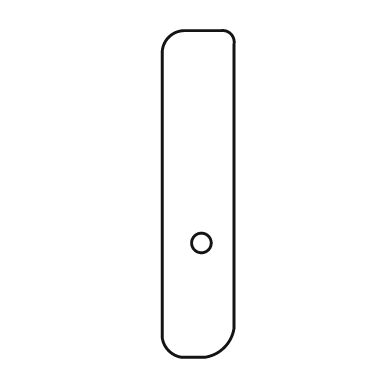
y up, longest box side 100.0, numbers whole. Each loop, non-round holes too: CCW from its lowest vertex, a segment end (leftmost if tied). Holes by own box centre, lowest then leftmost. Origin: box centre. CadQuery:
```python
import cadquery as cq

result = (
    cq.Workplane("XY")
    .moveTo(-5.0, -50.0)
    .lineTo(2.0, -50.0)
    .threePointArc((8.0, -47.0), (11.0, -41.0))
    .lineTo(11.0, 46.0)
    .threePointArc((10.0, 49.0), (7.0, 50.0))
    .lineTo(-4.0, 50.0)
    .threePointArc((-9.0, 48.0), (-11.0, 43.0))
    .lineTo(-11.0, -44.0)
    .threePointArc((-9.0, -48.0), (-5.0, -50.0))
    .close()
    .moveTo(1.0, -15.0)
    .circle(3.0)
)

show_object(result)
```